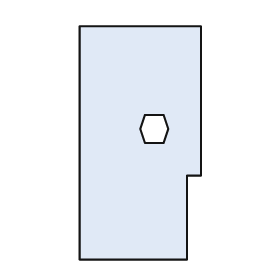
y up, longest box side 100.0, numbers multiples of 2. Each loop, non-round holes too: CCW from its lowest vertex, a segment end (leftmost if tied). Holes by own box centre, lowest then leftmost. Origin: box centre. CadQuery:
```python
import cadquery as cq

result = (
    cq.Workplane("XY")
    .moveTo(-26.0, -50.0)
    .lineTo(20.0, -50.0)
    .lineTo(20.0, -14.0)
    .lineTo(26.0, -14.0)
    .lineTo(26.0, 50.0)
    .lineTo(-26.0, 50.0)
    .close()
    .moveTo(2.0, 0.0)
    .lineTo(10.0, 0.0)
    .lineTo(12.0, 6.0)
    .lineTo(10.0, 12.0)
    .lineTo(2.0, 12.0)
    .lineTo(0.0, 6.0)
    .close()
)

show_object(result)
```